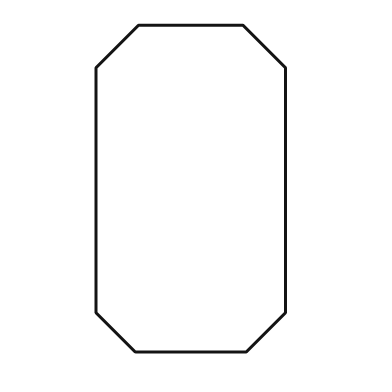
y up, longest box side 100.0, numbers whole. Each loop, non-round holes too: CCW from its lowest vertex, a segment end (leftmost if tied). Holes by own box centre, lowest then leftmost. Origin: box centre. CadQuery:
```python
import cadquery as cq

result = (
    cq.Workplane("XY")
    .moveTo(-17.0, -50.0)
    .lineTo(17.0, -50.0)
    .lineTo(29.0, -38.0)
    .lineTo(29.0, 37.0)
    .lineTo(16.0, 50.0)
    .lineTo(-16.0, 50.0)
    .lineTo(-29.0, 37.0)
    .lineTo(-29.0, -38.0)
    .close()
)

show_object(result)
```